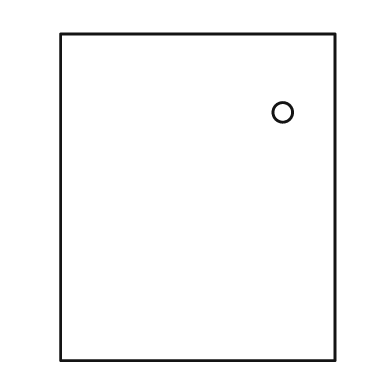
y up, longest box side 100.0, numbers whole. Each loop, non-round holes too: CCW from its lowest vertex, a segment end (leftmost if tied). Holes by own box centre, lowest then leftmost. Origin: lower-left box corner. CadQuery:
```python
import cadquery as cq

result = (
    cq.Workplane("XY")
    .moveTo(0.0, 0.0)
    .lineTo(84.0, 0.0)
    .lineTo(84.0, 100.0)
    .lineTo(0.0, 100.0)
    .close()
    .moveTo(68.0, 76.0)
    .circle(3.0)
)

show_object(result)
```